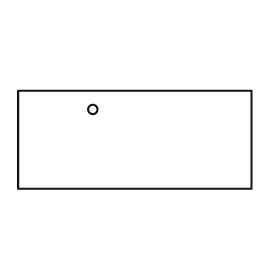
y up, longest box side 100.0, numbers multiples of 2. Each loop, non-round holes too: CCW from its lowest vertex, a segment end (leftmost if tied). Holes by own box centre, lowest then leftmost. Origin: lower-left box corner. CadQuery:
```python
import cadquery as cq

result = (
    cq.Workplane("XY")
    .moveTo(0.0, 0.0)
    .lineTo(100.0, 0.0)
    .lineTo(100.0, 42.0)
    .lineTo(0.0, 42.0)
    .close()
    .moveTo(32.0, 34.0)
    .circle(2.0)
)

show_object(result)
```